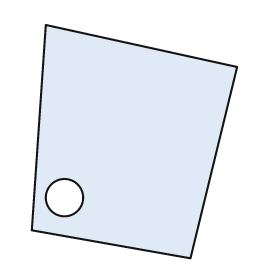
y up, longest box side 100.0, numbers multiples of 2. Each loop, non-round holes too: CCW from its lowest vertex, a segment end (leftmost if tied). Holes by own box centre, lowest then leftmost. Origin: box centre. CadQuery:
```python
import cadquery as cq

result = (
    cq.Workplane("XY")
    .moveTo(24.0, -50.0)
    .lineTo(44.0, 32.0)
    .lineTo(-38.0, 50.0)
    .lineTo(-44.0, -38.0)
    .close()
    .moveTo(-30.0, -24.0)
    .circle(8.0)
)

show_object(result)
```